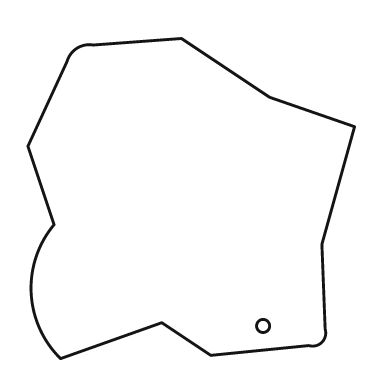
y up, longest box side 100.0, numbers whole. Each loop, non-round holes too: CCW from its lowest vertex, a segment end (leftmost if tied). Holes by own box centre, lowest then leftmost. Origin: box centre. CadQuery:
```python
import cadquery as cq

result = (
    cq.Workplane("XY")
    .moveTo(-40.0, -49.0)
    .lineTo(-9.0, -38.0)
    .lineTo(6.0, -48.0)
    .lineTo(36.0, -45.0)
    .threePointArc((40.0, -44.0), (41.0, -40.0))
    .lineTo(40.0, -14.0)
    .lineTo(50.0, 22.0)
    .lineTo(24.0, 31.0)
    .lineTo(-3.0, 49.0)
    .lineTo(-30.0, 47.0)
    .threePointArc((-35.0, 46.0), (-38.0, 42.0))
    .lineTo(-50.0, 16.0)
    .lineTo(-42.0, -8.0)
    .threePointArc((-49.0, -29.0), (-40.0, -49.0))
    .close()
    .moveTo(22.0, -39.0)
    .circle(2.0)
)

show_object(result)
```